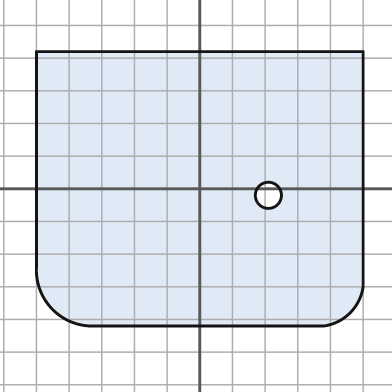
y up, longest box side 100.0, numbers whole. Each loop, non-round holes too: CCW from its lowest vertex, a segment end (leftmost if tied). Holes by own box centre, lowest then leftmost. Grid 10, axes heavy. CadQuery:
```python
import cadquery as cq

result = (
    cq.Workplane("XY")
    .moveTo(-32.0, -42.0)
    .lineTo(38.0, -42.0)
    .threePointArc((46.0, -38.0), (50.0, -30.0))
    .lineTo(50.0, 42.0)
    .lineTo(-50.0, 42.0)
    .lineTo(-50.0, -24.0)
    .threePointArc((-45.0, -37.0), (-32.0, -42.0))
    .close()
    .moveTo(21.0, -2.0)
    .circle(4.0)
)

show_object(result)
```